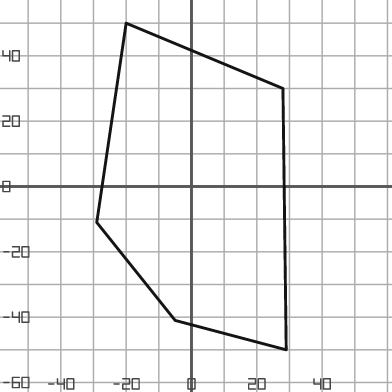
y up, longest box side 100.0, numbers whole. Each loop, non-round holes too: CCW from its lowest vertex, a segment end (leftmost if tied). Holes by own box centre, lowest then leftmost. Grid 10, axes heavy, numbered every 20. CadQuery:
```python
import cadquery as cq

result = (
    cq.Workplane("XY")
    .moveTo(29.0, -50.0)
    .lineTo(28.0, 30.0)
    .lineTo(-20.0, 50.0)
    .lineTo(-29.0, -11.0)
    .lineTo(-5.0, -41.0)
    .close()
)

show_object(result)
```